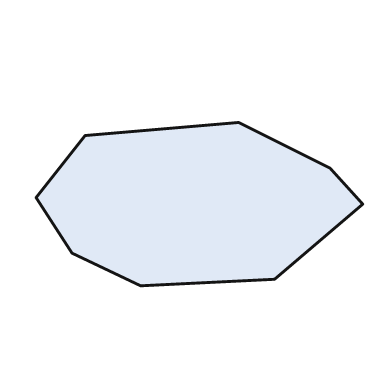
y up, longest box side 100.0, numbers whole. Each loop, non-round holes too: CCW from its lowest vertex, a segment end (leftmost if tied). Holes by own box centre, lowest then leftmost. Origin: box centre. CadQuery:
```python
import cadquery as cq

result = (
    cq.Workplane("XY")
    .moveTo(-18.0, -25.0)
    .lineTo(23.0, -23.0)
    .lineTo(50.0, 0.0)
    .lineTo(40.0, 11.0)
    .lineTo(12.0, 25.0)
    .lineTo(-35.0, 21.0)
    .lineTo(-50.0, 2.0)
    .lineTo(-39.0, -15.0)
    .close()
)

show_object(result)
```